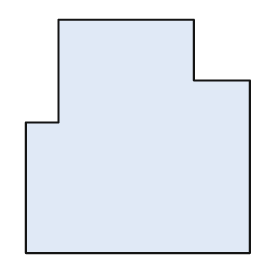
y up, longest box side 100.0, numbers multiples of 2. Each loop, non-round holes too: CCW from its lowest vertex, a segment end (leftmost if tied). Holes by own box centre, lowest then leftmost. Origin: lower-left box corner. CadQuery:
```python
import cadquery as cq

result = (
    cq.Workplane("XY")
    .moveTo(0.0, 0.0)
    .lineTo(96.0, 0.0)
    .lineTo(96.0, 74.0)
    .lineTo(72.0, 74.0)
    .lineTo(72.0, 100.0)
    .lineTo(14.0, 100.0)
    .lineTo(14.0, 56.0)
    .lineTo(0.0, 56.0)
    .close()
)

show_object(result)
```